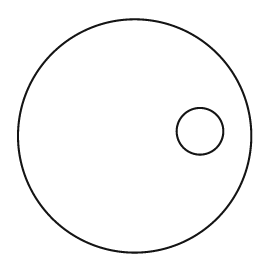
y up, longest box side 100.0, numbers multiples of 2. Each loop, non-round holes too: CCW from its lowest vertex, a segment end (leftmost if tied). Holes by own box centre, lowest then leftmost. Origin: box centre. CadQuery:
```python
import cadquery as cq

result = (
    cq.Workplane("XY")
    .moveTo(0.0, 0.0)
    .circle(50.0)
    .moveTo(28.0, 2.0)
    .circle(10.0)
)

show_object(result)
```